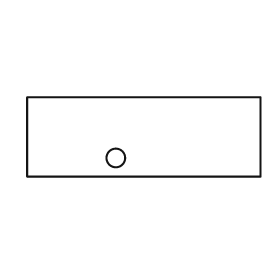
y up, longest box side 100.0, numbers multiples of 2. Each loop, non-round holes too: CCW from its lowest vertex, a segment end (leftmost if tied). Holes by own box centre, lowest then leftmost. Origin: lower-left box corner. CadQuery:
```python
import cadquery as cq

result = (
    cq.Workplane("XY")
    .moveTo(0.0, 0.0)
    .lineTo(100.0, 0.0)
    .lineTo(100.0, 34.0)
    .lineTo(0.0, 34.0)
    .close()
    .moveTo(38.0, 8.0)
    .circle(4.0)
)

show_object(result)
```